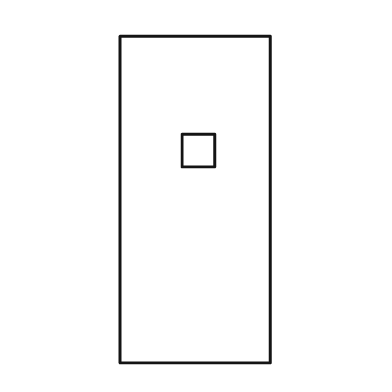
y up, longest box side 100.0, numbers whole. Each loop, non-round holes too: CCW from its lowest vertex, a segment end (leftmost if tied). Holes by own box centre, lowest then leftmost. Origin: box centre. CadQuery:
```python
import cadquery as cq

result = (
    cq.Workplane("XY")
    .moveTo(-23.0, -50.0)
    .lineTo(23.0, -50.0)
    .lineTo(23.0, 50.0)
    .lineTo(-23.0, 50.0)
    .close()
    .moveTo(-4.0, 10.0)
    .lineTo(6.0, 10.0)
    .lineTo(6.0, 20.0)
    .lineTo(-4.0, 20.0)
    .close()
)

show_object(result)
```